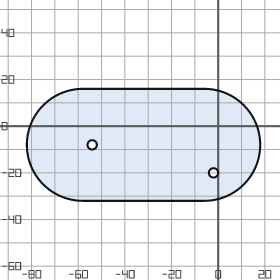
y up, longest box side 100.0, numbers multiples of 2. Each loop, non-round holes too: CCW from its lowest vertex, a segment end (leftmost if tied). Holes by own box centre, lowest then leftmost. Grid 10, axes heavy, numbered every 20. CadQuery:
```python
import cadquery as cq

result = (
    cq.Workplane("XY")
    .moveTo(-58.0, -32.0)
    .lineTo(-6.0, -32.0)
    .threePointArc((18.0, -8.0), (-6.0, 16.0))
    .lineTo(-58.0, 16.0)
    .threePointArc((-82.0, -8.0), (-58.0, -32.0))
    .close()
    .moveTo(-2.0, -20.0)
    .circle(2.0)
    .moveTo(-54.0, -8.0)
    .circle(2.0)
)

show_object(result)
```